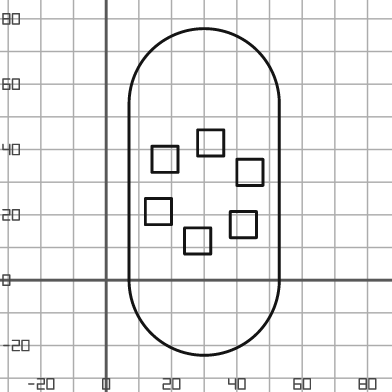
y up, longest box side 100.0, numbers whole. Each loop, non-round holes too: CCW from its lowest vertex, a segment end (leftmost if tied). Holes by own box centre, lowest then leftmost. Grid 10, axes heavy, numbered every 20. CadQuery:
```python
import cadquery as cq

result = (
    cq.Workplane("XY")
    .moveTo(7.0, 0.0)
    .threePointArc((30.0, -23.0), (53.0, 0.0))
    .lineTo(53.0, 54.0)
    .threePointArc((30.0, 77.0), (7.0, 54.0))
    .close()
    .moveTo(24.0, 8.0)
    .lineTo(32.0, 8.0)
    .lineTo(32.0, 16.0)
    .lineTo(24.0, 16.0)
    .close()
    .moveTo(38.0, 13.0)
    .lineTo(46.0, 13.0)
    .lineTo(46.0, 21.0)
    .lineTo(38.0, 21.0)
    .close()
    .moveTo(12.0, 17.0)
    .lineTo(20.0, 17.0)
    .lineTo(20.0, 25.0)
    .lineTo(12.0, 25.0)
    .close()
    .moveTo(40.0, 29.0)
    .lineTo(48.0, 29.0)
    .lineTo(48.0, 37.0)
    .lineTo(40.0, 37.0)
    .close()
    .moveTo(14.0, 33.0)
    .lineTo(22.0, 33.0)
    .lineTo(22.0, 41.0)
    .lineTo(14.0, 41.0)
    .close()
    .moveTo(28.0, 38.0)
    .lineTo(36.0, 38.0)
    .lineTo(36.0, 46.0)
    .lineTo(28.0, 46.0)
    .close()
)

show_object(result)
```